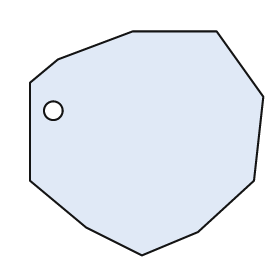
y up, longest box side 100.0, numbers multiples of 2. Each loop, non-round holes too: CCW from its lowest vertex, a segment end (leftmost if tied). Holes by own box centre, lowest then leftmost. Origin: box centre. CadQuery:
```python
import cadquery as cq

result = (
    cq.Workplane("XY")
    .moveTo(-2.0, -48.0)
    .lineTo(22.0, -38.0)
    .lineTo(46.0, -16.0)
    .lineTo(50.0, 20.0)
    .lineTo(30.0, 48.0)
    .lineTo(-6.0, 48.0)
    .lineTo(-38.0, 36.0)
    .lineTo(-50.0, 26.0)
    .lineTo(-50.0, -16.0)
    .lineTo(-26.0, -36.0)
    .close()
    .moveTo(-40.0, 14.0)
    .circle(4.0)
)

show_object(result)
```